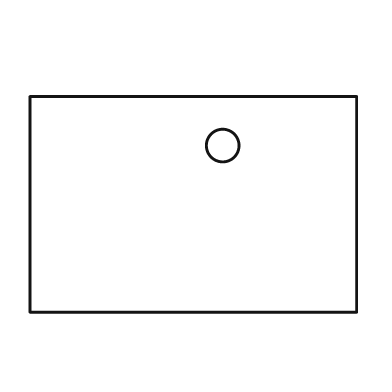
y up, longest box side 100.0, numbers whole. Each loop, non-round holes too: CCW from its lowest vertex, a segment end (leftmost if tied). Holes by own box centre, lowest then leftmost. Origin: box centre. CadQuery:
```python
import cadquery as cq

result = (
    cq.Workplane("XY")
    .moveTo(-50.0, -33.0)
    .lineTo(50.0, -33.0)
    .lineTo(50.0, 33.0)
    .lineTo(-50.0, 33.0)
    .close()
    .moveTo(9.0, 18.0)
    .circle(5.0)
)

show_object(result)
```